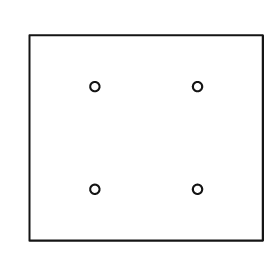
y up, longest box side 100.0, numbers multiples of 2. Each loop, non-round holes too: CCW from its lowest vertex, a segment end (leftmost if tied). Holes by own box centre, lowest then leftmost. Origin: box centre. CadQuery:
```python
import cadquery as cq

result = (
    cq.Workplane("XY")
    .moveTo(-50.0, -44.0)
    .lineTo(50.0, -44.0)
    .lineTo(50.0, 44.0)
    .lineTo(-50.0, 44.0)
    .close()
    .moveTo(-22.0, -22.0)
    .circle(2.0)
    .moveTo(22.0, -22.0)
    .circle(2.0)
    .moveTo(-22.0, 22.0)
    .circle(2.0)
    .moveTo(22.0, 22.0)
    .circle(2.0)
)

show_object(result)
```